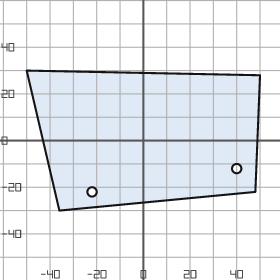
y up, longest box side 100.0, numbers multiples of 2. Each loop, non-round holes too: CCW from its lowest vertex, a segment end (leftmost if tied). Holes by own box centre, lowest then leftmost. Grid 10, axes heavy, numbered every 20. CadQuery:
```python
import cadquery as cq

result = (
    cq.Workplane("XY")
    .moveTo(-36.0, -30.0)
    .lineTo(48.0, -22.0)
    .lineTo(50.0, 28.0)
    .lineTo(-50.0, 30.0)
    .close()
    .moveTo(-22.0, -22.0)
    .circle(2.0)
    .moveTo(40.0, -12.0)
    .circle(2.0)
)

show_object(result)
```